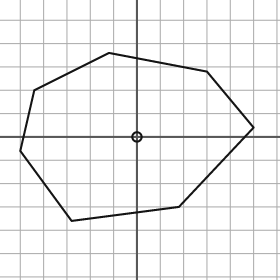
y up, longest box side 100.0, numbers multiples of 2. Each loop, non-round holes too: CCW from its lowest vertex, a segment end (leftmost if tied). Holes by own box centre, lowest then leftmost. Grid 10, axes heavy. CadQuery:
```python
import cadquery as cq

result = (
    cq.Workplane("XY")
    .moveTo(-28.0, -36.0)
    .lineTo(18.0, -30.0)
    .lineTo(50.0, 4.0)
    .lineTo(30.0, 28.0)
    .lineTo(-12.0, 36.0)
    .lineTo(-44.0, 20.0)
    .lineTo(-50.0, -6.0)
    .close()
    .moveTo(0.0, 0.0)
    .circle(2.0)
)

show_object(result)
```